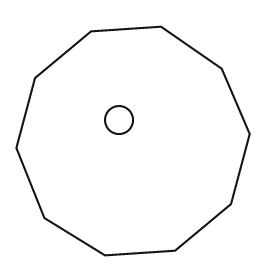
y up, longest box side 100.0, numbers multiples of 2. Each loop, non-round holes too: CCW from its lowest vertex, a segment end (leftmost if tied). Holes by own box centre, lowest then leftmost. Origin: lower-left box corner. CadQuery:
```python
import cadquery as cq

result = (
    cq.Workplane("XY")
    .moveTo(38.0, 0.0)
    .lineTo(68.0, 2.0)
    .lineTo(92.0, 22.0)
    .lineTo(100.0, 52.0)
    .lineTo(88.0, 80.0)
    .lineTo(62.0, 98.0)
    .lineTo(32.0, 96.0)
    .lineTo(8.0, 76.0)
    .lineTo(0.0, 46.0)
    .lineTo(12.0, 16.0)
    .close()
    .moveTo(44.0, 58.0)
    .circle(6.0)
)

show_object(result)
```